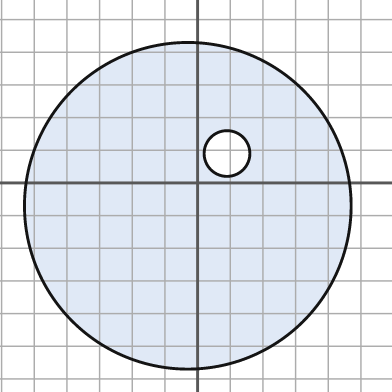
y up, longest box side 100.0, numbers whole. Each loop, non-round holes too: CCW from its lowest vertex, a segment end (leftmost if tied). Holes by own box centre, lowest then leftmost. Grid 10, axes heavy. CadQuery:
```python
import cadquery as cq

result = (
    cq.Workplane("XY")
    .moveTo(-3.0, -7.0)
    .circle(50.0)
    .moveTo(9.0, 9.0)
    .circle(7.0)
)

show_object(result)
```